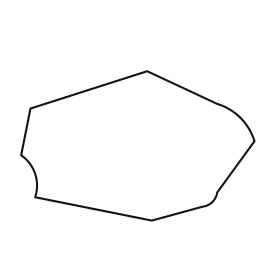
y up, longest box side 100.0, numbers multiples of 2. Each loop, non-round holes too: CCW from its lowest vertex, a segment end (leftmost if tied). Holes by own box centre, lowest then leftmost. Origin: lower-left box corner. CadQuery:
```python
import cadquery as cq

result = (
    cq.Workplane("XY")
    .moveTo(56.0, 0.0)
    .lineTo(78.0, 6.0)
    .threePointArc((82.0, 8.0), (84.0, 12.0))
    .lineTo(100.0, 34.0)
    .threePointArc((94.0, 44.0), (84.0, 50.0))
    .lineTo(54.0, 64.0)
    .lineTo(4.0, 48.0)
    .lineTo(0.0, 28.0)
    .threePointArc((6.0, 20.0), (6.0, 10.0))
    .close()
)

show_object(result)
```